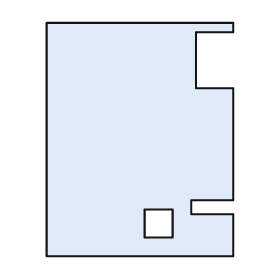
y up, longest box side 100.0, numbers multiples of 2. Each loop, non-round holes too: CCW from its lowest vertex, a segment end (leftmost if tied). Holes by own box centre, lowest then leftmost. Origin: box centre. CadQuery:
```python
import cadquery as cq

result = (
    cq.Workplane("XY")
    .moveTo(-40.0, -50.0)
    .lineTo(40.0, -50.0)
    .lineTo(40.0, -32.0)
    .lineTo(22.0, -32.0)
    .lineTo(22.0, -26.0)
    .lineTo(40.0, -26.0)
    .lineTo(40.0, 22.0)
    .lineTo(24.0, 22.0)
    .lineTo(24.0, 46.0)
    .lineTo(40.0, 46.0)
    .lineTo(40.0, 50.0)
    .lineTo(-40.0, 50.0)
    .close()
    .moveTo(2.0, -42.0)
    .lineTo(14.0, -42.0)
    .lineTo(14.0, -30.0)
    .lineTo(2.0, -30.0)
    .close()
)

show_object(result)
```